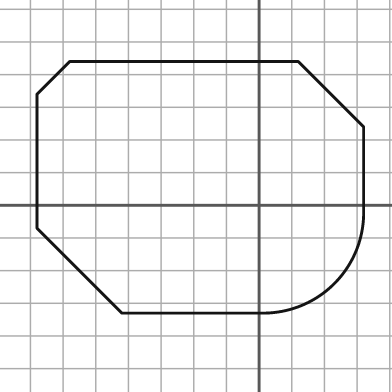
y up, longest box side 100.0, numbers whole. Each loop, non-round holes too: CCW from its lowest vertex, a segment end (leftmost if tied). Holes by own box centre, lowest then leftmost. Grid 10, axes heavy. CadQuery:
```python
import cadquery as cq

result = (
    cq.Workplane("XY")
    .moveTo(-42.0, -33.0)
    .lineTo(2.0, -33.0)
    .threePointArc((23.0, -24.0), (32.0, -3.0))
    .lineTo(32.0, 24.0)
    .lineTo(12.0, 44.0)
    .lineTo(-58.0, 44.0)
    .lineTo(-68.0, 34.0)
    .lineTo(-68.0, -7.0)
    .close()
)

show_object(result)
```